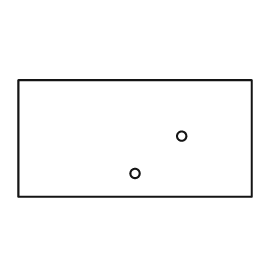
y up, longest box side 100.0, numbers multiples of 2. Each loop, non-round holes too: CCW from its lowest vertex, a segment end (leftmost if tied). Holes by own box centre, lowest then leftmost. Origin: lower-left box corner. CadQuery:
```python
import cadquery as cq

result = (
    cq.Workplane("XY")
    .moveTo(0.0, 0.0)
    .lineTo(100.0, 0.0)
    .lineTo(100.0, 50.0)
    .lineTo(0.0, 50.0)
    .close()
    .moveTo(50.0, 10.0)
    .circle(2.0)
    .moveTo(70.0, 26.0)
    .circle(2.0)
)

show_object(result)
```